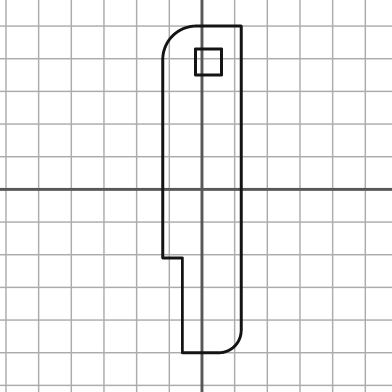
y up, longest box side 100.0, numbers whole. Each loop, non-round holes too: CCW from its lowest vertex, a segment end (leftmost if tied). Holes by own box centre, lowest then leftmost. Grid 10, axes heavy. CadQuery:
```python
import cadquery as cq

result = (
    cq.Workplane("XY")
    .moveTo(-6.0, -50.0)
    .lineTo(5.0, -50.0)
    .threePointArc((10.0, -48.0), (12.0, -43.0))
    .lineTo(12.0, 50.0)
    .lineTo(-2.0, 50.0)
    .threePointArc((-9.0, 47.0), (-12.0, 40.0))
    .lineTo(-12.0, -21.0)
    .lineTo(-6.0, -21.0)
    .close()
    .moveTo(-2.0, 35.0)
    .lineTo(6.0, 35.0)
    .lineTo(6.0, 43.0)
    .lineTo(-2.0, 43.0)
    .close()
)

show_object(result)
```